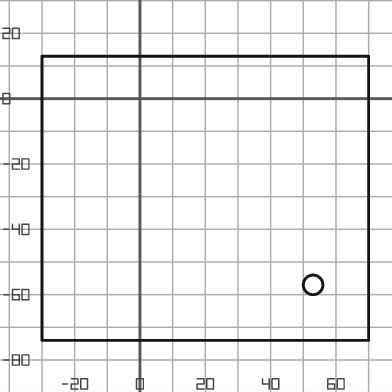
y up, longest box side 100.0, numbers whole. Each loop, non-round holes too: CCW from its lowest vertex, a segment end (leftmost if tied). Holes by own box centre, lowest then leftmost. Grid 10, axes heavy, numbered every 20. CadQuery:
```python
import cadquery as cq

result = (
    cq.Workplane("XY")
    .moveTo(-30.0, -74.0)
    .lineTo(70.0, -74.0)
    .lineTo(70.0, 13.0)
    .lineTo(-30.0, 13.0)
    .close()
    .moveTo(53.0, -57.0)
    .circle(3.0)
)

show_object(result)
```